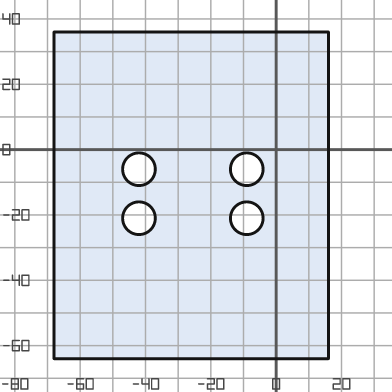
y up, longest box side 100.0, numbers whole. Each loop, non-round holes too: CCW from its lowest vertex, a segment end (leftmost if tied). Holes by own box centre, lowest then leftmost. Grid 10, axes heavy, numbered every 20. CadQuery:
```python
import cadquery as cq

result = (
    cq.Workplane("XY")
    .moveTo(-68.0, -64.0)
    .lineTo(16.0, -64.0)
    .lineTo(16.0, 36.0)
    .lineTo(-68.0, 36.0)
    .close()
    .moveTo(-42.0, -21.0)
    .circle(5.0)
    .moveTo(-9.0, -21.0)
    .circle(5.0)
    .moveTo(-42.0, -6.0)
    .circle(5.0)
    .moveTo(-9.0, -6.0)
    .circle(5.0)
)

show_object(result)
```